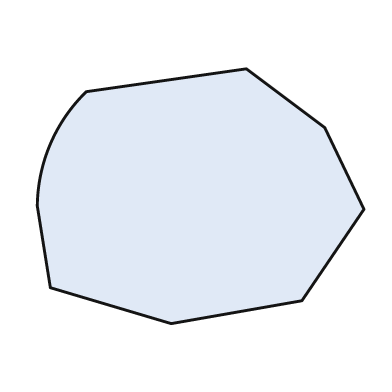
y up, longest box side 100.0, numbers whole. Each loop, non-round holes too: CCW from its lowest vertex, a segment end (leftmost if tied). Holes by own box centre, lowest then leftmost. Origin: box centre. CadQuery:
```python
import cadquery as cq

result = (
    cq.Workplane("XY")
    .moveTo(-9.0, -39.0)
    .lineTo(31.0, -32.0)
    .lineTo(50.0, -4.0)
    .lineTo(38.0, 21.0)
    .lineTo(14.0, 39.0)
    .lineTo(-35.0, 32.0)
    .threePointArc((-46.0, 16.0), (-50.0, -3.0))
    .lineTo(-46.0, -28.0)
    .close()
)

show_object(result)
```